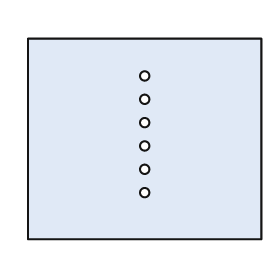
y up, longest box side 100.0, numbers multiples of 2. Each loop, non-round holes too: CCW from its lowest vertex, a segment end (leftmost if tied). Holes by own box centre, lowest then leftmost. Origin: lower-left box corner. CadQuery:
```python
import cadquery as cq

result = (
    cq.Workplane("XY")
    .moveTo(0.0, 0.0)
    .lineTo(100.0, 0.0)
    .lineTo(100.0, 86.0)
    .lineTo(0.0, 86.0)
    .close()
    .moveTo(50.0, 20.0)
    .circle(2.0)
    .moveTo(50.0, 30.0)
    .circle(2.0)
    .moveTo(50.0, 40.0)
    .circle(2.0)
    .moveTo(50.0, 50.0)
    .circle(2.0)
    .moveTo(50.0, 60.0)
    .circle(2.0)
    .moveTo(50.0, 70.0)
    .circle(2.0)
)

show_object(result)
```